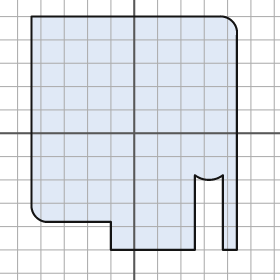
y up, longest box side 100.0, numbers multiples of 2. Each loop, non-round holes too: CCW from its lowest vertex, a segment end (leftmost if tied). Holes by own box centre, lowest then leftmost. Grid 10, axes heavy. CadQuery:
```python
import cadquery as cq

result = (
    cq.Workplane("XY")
    .moveTo(-10.0, -50.0)
    .lineTo(26.0, -50.0)
    .lineTo(26.0, -18.0)
    .threePointArc((32.0, -20.0), (38.0, -18.0))
    .lineTo(38.0, -50.0)
    .lineTo(44.0, -50.0)
    .lineTo(44.0, 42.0)
    .threePointArc((42.0, 48.0), (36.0, 50.0))
    .lineTo(-44.0, 50.0)
    .lineTo(-44.0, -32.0)
    .threePointArc((-42.0, -36.0), (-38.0, -38.0))
    .lineTo(-10.0, -38.0)
    .close()
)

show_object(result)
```